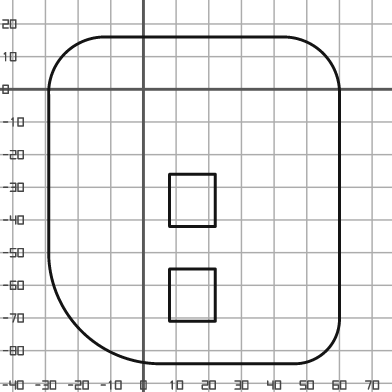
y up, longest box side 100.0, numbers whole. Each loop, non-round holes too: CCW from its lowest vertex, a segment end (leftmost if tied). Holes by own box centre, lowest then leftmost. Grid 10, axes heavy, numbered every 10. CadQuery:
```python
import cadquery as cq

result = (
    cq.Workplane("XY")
    .moveTo(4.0, -84.0)
    .lineTo(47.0, -84.0)
    .threePointArc((56.0, -80.0), (60.0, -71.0))
    .lineTo(60.0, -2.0)
    .threePointArc((55.0, 11.0), (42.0, 16.0))
    .lineTo(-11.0, 16.0)
    .threePointArc((-24.0, 11.0), (-29.0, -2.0))
    .lineTo(-29.0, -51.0)
    .threePointArc((-19.0, -74.0), (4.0, -84.0))
    .close()
    .moveTo(8.0, -71.0)
    .lineTo(22.0, -71.0)
    .lineTo(22.0, -55.0)
    .lineTo(8.0, -55.0)
    .close()
    .moveTo(8.0, -42.0)
    .lineTo(22.0, -42.0)
    .lineTo(22.0, -26.0)
    .lineTo(8.0, -26.0)
    .close()
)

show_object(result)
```